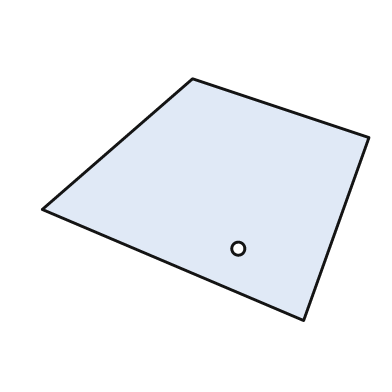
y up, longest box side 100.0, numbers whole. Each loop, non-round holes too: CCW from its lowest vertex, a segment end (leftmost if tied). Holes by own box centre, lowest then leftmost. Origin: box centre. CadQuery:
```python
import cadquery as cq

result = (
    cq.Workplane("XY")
    .moveTo(30.0, -37.0)
    .lineTo(50.0, 19.0)
    .lineTo(-4.0, 37.0)
    .lineTo(-50.0, -3.0)
    .close()
    .moveTo(10.0, -15.0)
    .circle(2.0)
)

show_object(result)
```